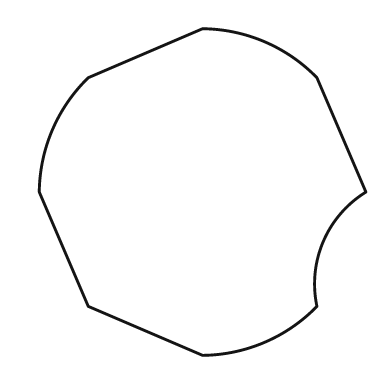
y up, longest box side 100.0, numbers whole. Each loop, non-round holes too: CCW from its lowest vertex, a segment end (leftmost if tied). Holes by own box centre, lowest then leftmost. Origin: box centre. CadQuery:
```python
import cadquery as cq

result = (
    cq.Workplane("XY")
    .moveTo(0.0, -50.0)
    .threePointArc((19.0, -46.0), (35.0, -35.0))
    .threePointArc((37.0, -15.0), (50.0, 0.0))
    .lineTo(35.0, 35.0)
    .threePointArc((19.0, 46.0), (0.0, 50.0))
    .lineTo(-35.0, 35.0)
    .threePointArc((-46.0, 19.0), (-50.0, 0.0))
    .lineTo(-35.0, -35.0)
    .close()
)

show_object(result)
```